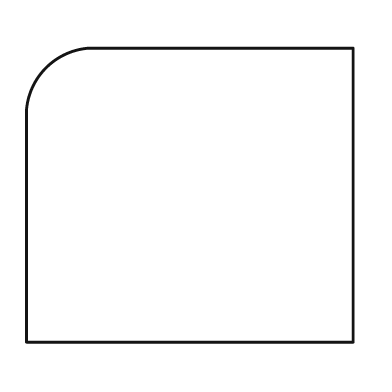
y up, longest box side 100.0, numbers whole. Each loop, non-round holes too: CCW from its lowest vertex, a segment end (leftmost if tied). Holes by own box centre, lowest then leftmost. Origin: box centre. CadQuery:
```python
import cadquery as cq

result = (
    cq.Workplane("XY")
    .moveTo(-50.0, -45.0)
    .lineTo(50.0, -45.0)
    .lineTo(50.0, 45.0)
    .lineTo(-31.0, 45.0)
    .threePointArc((-44.0, 39.0), (-50.0, 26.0))
    .close()
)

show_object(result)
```